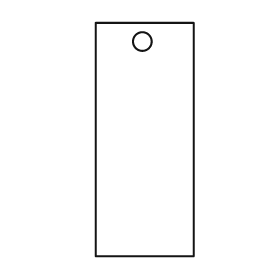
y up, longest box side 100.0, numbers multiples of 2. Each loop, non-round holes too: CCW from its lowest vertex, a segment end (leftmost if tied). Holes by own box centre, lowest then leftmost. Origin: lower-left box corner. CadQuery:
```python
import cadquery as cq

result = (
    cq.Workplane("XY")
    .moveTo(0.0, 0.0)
    .lineTo(42.0, 0.0)
    .lineTo(42.0, 100.0)
    .lineTo(0.0, 100.0)
    .close()
    .moveTo(20.0, 92.0)
    .circle(4.0)
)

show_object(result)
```